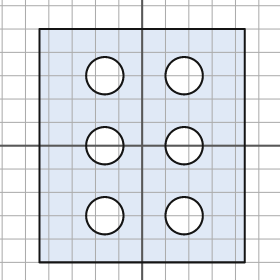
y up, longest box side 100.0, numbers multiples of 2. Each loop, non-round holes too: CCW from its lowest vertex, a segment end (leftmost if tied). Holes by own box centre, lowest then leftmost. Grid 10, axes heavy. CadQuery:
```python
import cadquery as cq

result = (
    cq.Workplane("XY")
    .moveTo(-44.0, -50.0)
    .lineTo(44.0, -50.0)
    .lineTo(44.0, 50.0)
    .lineTo(-44.0, 50.0)
    .close()
    .moveTo(-16.0, -30.0)
    .circle(8.0)
    .moveTo(18.0, -30.0)
    .circle(8.0)
    .moveTo(-16.0, 0.0)
    .circle(8.0)
    .moveTo(18.0, 0.0)
    .circle(8.0)
    .moveTo(-16.0, 30.0)
    .circle(8.0)
    .moveTo(18.0, 30.0)
    .circle(8.0)
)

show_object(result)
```